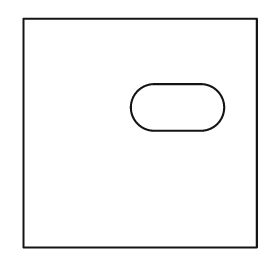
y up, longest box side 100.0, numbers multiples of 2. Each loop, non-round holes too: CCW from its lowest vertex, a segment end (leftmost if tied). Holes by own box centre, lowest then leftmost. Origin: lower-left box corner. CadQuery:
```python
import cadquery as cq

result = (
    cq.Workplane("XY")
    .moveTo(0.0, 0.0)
    .lineTo(100.0, 0.0)
    .lineTo(100.0, 98.0)
    .lineTo(0.0, 98.0)
    .close()
    .moveTo(56.0, 50.0)
    .lineTo(76.0, 50.0)
    .threePointArc((86.0, 60.0), (76.0, 70.0))
    .lineTo(56.0, 70.0)
    .threePointArc((46.0, 60.0), (56.0, 50.0))
    .close()
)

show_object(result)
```